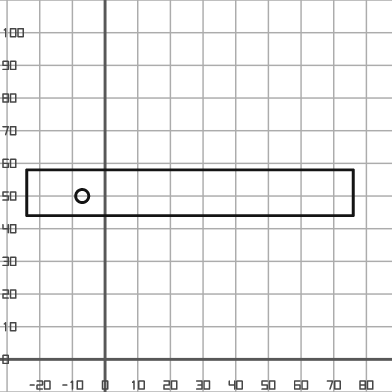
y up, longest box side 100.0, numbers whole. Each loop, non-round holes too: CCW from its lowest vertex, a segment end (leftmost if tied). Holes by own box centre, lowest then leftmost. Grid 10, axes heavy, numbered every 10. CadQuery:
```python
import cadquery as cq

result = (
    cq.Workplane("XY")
    .moveTo(-24.0, 44.0)
    .lineTo(76.0, 44.0)
    .lineTo(76.0, 58.0)
    .lineTo(-24.0, 58.0)
    .close()
    .moveTo(-7.0, 50.0)
    .circle(2.0)
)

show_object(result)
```